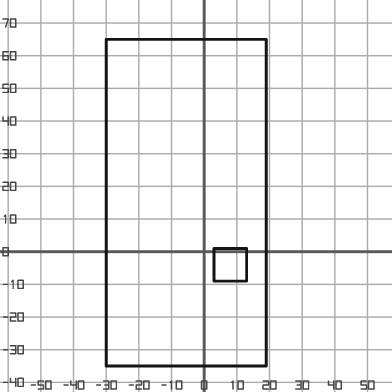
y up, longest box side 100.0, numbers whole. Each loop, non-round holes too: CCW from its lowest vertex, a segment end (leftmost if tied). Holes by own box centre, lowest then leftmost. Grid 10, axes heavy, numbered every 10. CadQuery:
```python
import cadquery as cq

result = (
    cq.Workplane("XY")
    .moveTo(-30.0, -35.0)
    .lineTo(19.0, -35.0)
    .lineTo(19.0, 65.0)
    .lineTo(-30.0, 65.0)
    .close()
    .moveTo(3.0, -9.0)
    .lineTo(13.0, -9.0)
    .lineTo(13.0, 1.0)
    .lineTo(3.0, 1.0)
    .close()
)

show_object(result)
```